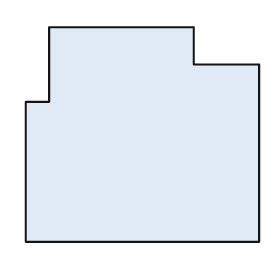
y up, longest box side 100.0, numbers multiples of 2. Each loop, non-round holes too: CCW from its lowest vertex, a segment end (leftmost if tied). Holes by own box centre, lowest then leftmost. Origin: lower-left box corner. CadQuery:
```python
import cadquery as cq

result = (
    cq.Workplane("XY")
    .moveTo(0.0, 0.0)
    .lineTo(100.0, 0.0)
    .lineTo(100.0, 76.0)
    .lineTo(72.0, 76.0)
    .lineTo(72.0, 92.0)
    .lineTo(10.0, 92.0)
    .lineTo(10.0, 60.0)
    .lineTo(0.0, 60.0)
    .close()
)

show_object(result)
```